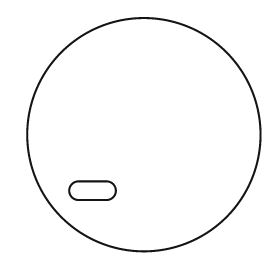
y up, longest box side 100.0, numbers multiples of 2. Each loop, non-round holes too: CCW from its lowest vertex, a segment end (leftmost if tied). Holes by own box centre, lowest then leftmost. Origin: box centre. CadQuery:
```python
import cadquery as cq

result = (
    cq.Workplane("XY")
    .moveTo(0.0, 0.0)
    .circle(50.0)
    .moveTo(-28.0, -28.0)
    .lineTo(-16.0, -28.0)
    .threePointArc((-12.0, -24.0), (-16.0, -20.0))
    .lineTo(-28.0, -20.0)
    .threePointArc((-32.0, -24.0), (-28.0, -28.0))
    .close()
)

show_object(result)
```